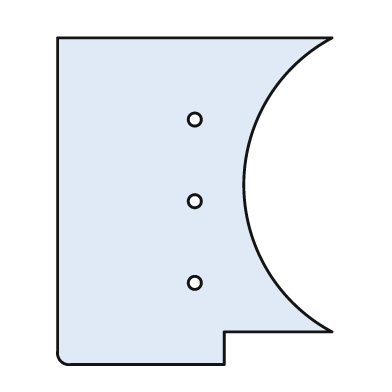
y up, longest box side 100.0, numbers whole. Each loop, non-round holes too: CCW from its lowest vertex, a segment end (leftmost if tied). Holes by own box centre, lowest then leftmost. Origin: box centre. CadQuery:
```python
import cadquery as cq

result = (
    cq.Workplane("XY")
    .moveTo(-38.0, -50.0)
    .lineTo(9.0, -50.0)
    .lineTo(9.0, -40.0)
    .lineTo(42.0, -40.0)
    .threePointArc((15.0, 5.0), (42.0, 50.0))
    .lineTo(-42.0, 50.0)
    .lineTo(-42.0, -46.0)
    .threePointArc((-41.0, -49.0), (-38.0, -50.0))
    .close()
    .moveTo(0.0, -25.0)
    .circle(2.0)
    .moveTo(0.0, 0.0)
    .circle(2.0)
    .moveTo(0.0, 25.0)
    .circle(2.0)
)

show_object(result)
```